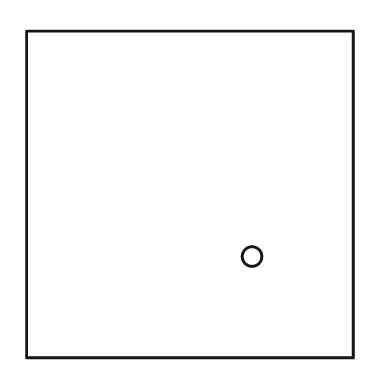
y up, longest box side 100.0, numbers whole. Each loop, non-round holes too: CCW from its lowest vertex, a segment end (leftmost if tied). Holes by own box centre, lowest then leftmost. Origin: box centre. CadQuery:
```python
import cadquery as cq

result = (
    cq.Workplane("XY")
    .moveTo(-50.0, -50.0)
    .lineTo(50.0, -50.0)
    .lineTo(50.0, 50.0)
    .lineTo(-50.0, 50.0)
    .close()
    .moveTo(19.0, -19.0)
    .circle(3.0)
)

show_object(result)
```